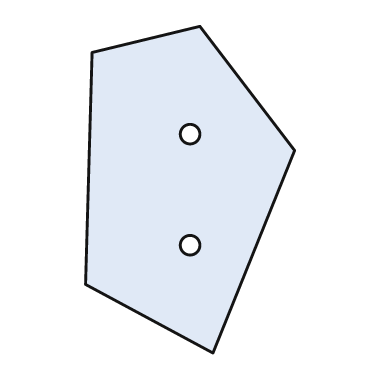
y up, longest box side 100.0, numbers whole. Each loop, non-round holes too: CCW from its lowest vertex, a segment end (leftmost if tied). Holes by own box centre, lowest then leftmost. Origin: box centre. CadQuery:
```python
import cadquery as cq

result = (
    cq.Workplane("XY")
    .moveTo(7.0, -50.0)
    .lineTo(32.0, 12.0)
    .lineTo(3.0, 50.0)
    .lineTo(-30.0, 42.0)
    .lineTo(-32.0, -29.0)
    .close()
    .moveTo(0.0, -17.0)
    .circle(3.0)
    .moveTo(0.0, 17.0)
    .circle(3.0)
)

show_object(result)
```